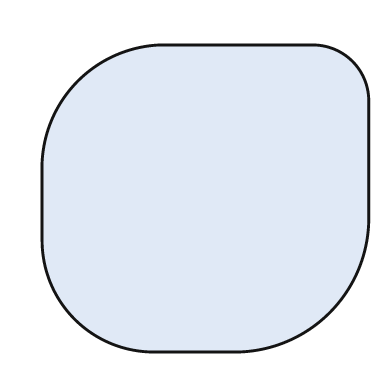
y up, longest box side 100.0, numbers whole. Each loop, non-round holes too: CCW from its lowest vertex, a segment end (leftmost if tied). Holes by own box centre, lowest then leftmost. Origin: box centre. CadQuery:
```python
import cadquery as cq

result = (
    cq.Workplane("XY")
    .moveTo(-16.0, -47.0)
    .lineTo(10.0, -47.0)
    .threePointArc((38.0, -35.0), (50.0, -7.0))
    .lineTo(50.0, 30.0)
    .threePointArc((45.0, 42.0), (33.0, 47.0))
    .lineTo(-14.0, 47.0)
    .threePointArc((-39.0, 36.0), (-50.0, 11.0))
    .lineTo(-50.0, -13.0)
    .threePointArc((-40.0, -37.0), (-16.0, -47.0))
    .close()
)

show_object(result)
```